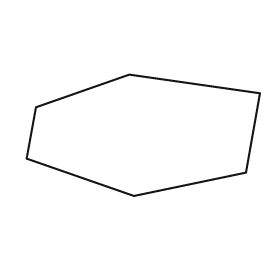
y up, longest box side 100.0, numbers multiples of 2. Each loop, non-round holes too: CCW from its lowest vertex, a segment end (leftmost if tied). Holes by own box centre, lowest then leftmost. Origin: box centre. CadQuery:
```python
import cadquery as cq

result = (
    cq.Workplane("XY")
    .moveTo(-4.0, -26.0)
    .lineTo(44.0, -16.0)
    .lineTo(50.0, 18.0)
    .lineTo(-6.0, 26.0)
    .lineTo(-46.0, 12.0)
    .lineTo(-50.0, -10.0)
    .close()
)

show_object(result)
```